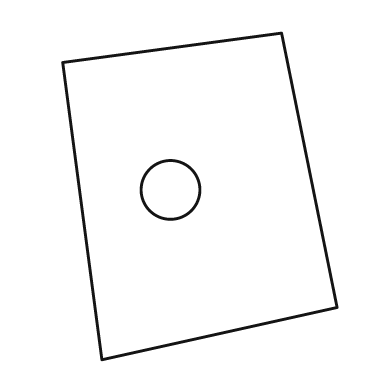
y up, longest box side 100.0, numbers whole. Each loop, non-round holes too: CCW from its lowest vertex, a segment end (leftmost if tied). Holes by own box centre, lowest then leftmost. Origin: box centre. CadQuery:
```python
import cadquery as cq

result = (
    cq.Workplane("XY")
    .moveTo(-30.0, -50.0)
    .lineTo(42.0, -34.0)
    .lineTo(25.0, 50.0)
    .lineTo(-42.0, 41.0)
    .close()
    .moveTo(-9.0, 2.0)
    .circle(9.0)
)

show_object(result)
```